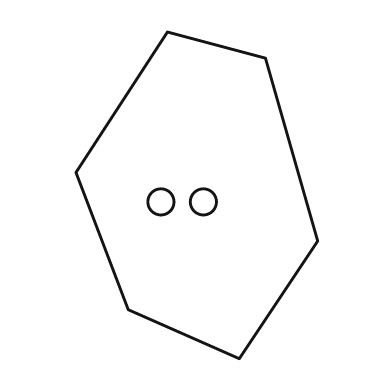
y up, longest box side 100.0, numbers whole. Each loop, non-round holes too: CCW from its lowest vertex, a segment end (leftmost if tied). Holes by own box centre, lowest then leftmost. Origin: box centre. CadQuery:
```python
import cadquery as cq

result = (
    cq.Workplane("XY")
    .moveTo(13.0, -50.0)
    .lineTo(37.0, -14.0)
    .lineTo(21.0, 42.0)
    .lineTo(-9.0, 50.0)
    .lineTo(-37.0, 7.0)
    .lineTo(-21.0, -35.0)
    .close()
    .moveTo(-11.0, -2.0)
    .circle(4.0)
    .moveTo(2.0, -2.0)
    .circle(4.0)
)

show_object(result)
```